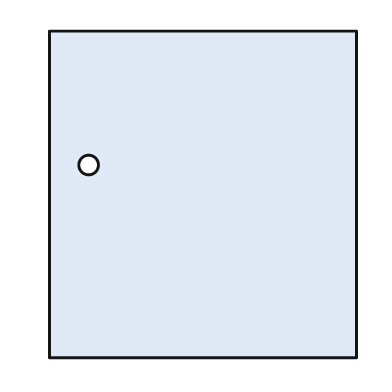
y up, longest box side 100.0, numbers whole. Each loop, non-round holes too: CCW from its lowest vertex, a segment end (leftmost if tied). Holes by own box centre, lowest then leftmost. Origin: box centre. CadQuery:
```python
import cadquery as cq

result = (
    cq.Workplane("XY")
    .moveTo(-47.0, -50.0)
    .lineTo(47.0, -50.0)
    .lineTo(47.0, 50.0)
    .lineTo(-47.0, 50.0)
    .close()
    .moveTo(-35.0, 9.0)
    .circle(3.0)
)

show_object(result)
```